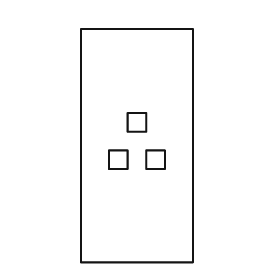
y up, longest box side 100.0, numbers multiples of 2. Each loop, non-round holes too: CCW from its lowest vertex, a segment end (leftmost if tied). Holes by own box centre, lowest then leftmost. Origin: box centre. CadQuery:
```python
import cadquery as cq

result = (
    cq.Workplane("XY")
    .moveTo(-24.0, -50.0)
    .lineTo(24.0, -50.0)
    .lineTo(24.0, 50.0)
    .lineTo(-24.0, 50.0)
    .close()
    .moveTo(-12.0, -10.0)
    .lineTo(-4.0, -10.0)
    .lineTo(-4.0, -2.0)
    .lineTo(-12.0, -2.0)
    .close()
    .moveTo(4.0, -10.0)
    .lineTo(12.0, -10.0)
    .lineTo(12.0, -2.0)
    .lineTo(4.0, -2.0)
    .close()
    .moveTo(-4.0, 6.0)
    .lineTo(4.0, 6.0)
    .lineTo(4.0, 14.0)
    .lineTo(-4.0, 14.0)
    .close()
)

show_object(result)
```